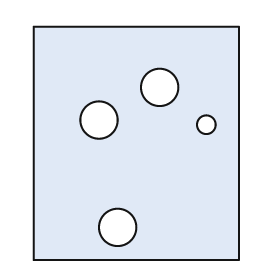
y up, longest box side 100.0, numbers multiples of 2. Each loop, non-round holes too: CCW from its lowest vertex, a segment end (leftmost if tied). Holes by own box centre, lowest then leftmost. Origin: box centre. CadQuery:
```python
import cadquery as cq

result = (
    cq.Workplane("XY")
    .moveTo(-44.0, -50.0)
    .lineTo(44.0, -50.0)
    .lineTo(44.0, 50.0)
    .lineTo(-44.0, 50.0)
    .close()
    .moveTo(-8.0, -36.0)
    .circle(8.0)
    .moveTo(30.0, 8.0)
    .circle(4.0)
    .moveTo(-16.0, 10.0)
    .circle(8.0)
    .moveTo(10.0, 24.0)
    .circle(8.0)
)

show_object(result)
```